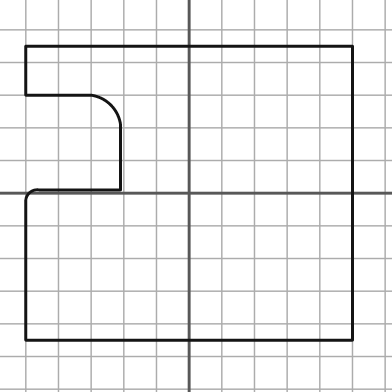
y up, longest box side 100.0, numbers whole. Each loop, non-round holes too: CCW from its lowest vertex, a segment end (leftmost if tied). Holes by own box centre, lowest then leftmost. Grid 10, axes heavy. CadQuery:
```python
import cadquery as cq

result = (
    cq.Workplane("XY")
    .moveTo(-50.0, -45.0)
    .lineTo(50.0, -45.0)
    .lineTo(50.0, 45.0)
    .lineTo(-50.0, 45.0)
    .lineTo(-50.0, 30.0)
    .lineTo(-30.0, 30.0)
    .threePointArc((-24.0, 27.0), (-21.0, 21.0))
    .lineTo(-21.0, 1.0)
    .lineTo(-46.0, 1.0)
    .threePointArc((-49.0, 0.0), (-50.0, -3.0))
    .close()
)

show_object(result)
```